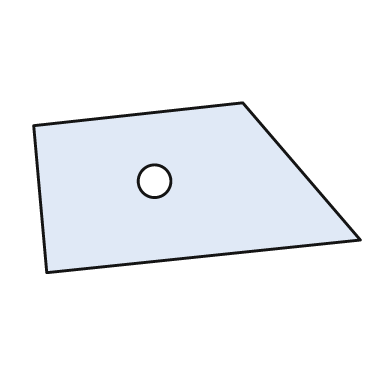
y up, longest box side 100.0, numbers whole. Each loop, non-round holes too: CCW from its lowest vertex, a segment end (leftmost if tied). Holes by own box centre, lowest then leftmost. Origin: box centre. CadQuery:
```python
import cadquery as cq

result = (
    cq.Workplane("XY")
    .moveTo(-46.0, -26.0)
    .lineTo(50.0, -16.0)
    .lineTo(14.0, 26.0)
    .lineTo(-50.0, 19.0)
    .close()
    .moveTo(-13.0, 2.0)
    .circle(5.0)
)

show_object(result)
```